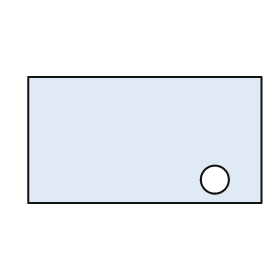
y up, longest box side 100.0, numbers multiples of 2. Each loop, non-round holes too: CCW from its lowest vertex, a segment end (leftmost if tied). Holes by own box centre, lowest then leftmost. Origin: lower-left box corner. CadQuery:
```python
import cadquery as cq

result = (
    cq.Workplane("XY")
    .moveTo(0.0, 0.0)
    .lineTo(100.0, 0.0)
    .lineTo(100.0, 54.0)
    .lineTo(0.0, 54.0)
    .close()
    .moveTo(80.0, 10.0)
    .circle(6.0)
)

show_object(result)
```